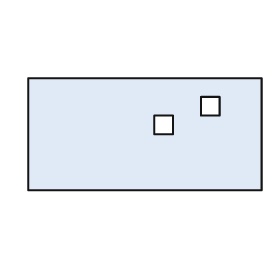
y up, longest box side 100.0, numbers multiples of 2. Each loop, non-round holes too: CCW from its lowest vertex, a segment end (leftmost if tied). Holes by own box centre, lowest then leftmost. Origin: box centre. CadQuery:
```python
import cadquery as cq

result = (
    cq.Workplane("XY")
    .moveTo(-50.0, -24.0)
    .lineTo(50.0, -24.0)
    .lineTo(50.0, 24.0)
    .lineTo(-50.0, 24.0)
    .close()
    .moveTo(4.0, 0.0)
    .lineTo(12.0, 0.0)
    .lineTo(12.0, 8.0)
    .lineTo(4.0, 8.0)
    .close()
    .moveTo(24.0, 8.0)
    .lineTo(32.0, 8.0)
    .lineTo(32.0, 16.0)
    .lineTo(24.0, 16.0)
    .close()
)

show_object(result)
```